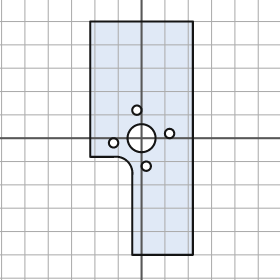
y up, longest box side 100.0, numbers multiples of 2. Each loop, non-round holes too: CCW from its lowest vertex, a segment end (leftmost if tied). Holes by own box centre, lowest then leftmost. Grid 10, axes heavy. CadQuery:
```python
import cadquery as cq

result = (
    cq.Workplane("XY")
    .moveTo(-4.0, -50.0)
    .lineTo(22.0, -50.0)
    .lineTo(22.0, 50.0)
    .lineTo(-22.0, 50.0)
    .lineTo(-22.0, -8.0)
    .lineTo(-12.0, -8.0)
    .threePointArc((-6.0, -10.0), (-4.0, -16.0))
    .close()
    .moveTo(2.0, -12.0)
    .circle(2.0)
    .moveTo(-12.0, -2.0)
    .circle(2.0)
    .moveTo(0.0, 0.0)
    .circle(6.0)
    .moveTo(12.0, 2.0)
    .circle(2.0)
    .moveTo(-2.0, 12.0)
    .circle(2.0)
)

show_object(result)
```